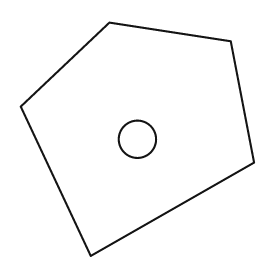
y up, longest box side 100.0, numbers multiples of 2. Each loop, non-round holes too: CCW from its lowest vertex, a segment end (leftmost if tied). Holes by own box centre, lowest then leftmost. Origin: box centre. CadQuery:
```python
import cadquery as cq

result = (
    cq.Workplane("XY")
    .moveTo(-20.0, -50.0)
    .lineTo(50.0, -10.0)
    .lineTo(40.0, 42.0)
    .lineTo(-12.0, 50.0)
    .lineTo(-50.0, 14.0)
    .close()
    .moveTo(0.0, 0.0)
    .circle(8.0)
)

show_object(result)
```